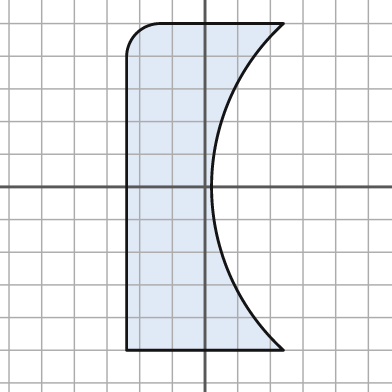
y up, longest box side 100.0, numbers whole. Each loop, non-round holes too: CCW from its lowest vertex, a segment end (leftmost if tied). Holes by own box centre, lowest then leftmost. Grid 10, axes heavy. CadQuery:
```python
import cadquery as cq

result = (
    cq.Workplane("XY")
    .moveTo(-24.0, -50.0)
    .lineTo(24.0, -50.0)
    .threePointArc((2.0, 0.0), (24.0, 50.0))
    .lineTo(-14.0, 50.0)
    .threePointArc((-21.0, 47.0), (-24.0, 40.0))
    .close()
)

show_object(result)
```